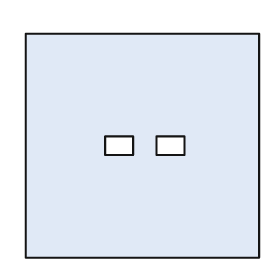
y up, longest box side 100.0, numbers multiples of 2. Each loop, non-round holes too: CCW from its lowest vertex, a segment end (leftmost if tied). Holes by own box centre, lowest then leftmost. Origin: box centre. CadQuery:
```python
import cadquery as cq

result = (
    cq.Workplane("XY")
    .moveTo(-50.0, -48.0)
    .lineTo(50.0, -48.0)
    .lineTo(50.0, 48.0)
    .lineTo(-50.0, 48.0)
    .close()
    .moveTo(-16.0, -4.0)
    .lineTo(-4.0, -4.0)
    .lineTo(-4.0, 4.0)
    .lineTo(-16.0, 4.0)
    .close()
    .moveTo(6.0, -4.0)
    .lineTo(18.0, -4.0)
    .lineTo(18.0, 4.0)
    .lineTo(6.0, 4.0)
    .close()
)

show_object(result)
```